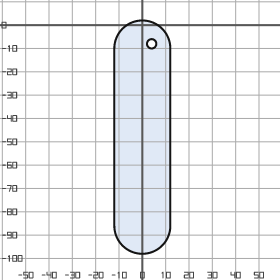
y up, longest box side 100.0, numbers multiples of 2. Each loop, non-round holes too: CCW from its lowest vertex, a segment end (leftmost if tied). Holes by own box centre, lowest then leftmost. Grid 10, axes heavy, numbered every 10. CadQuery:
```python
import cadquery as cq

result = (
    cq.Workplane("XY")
    .moveTo(-12.0, -86.0)
    .threePointArc((0.0, -98.0), (12.0, -86.0))
    .lineTo(12.0, -10.0)
    .threePointArc((0.0, 2.0), (-12.0, -10.0))
    .close()
    .moveTo(4.0, -8.0)
    .circle(2.0)
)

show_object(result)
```